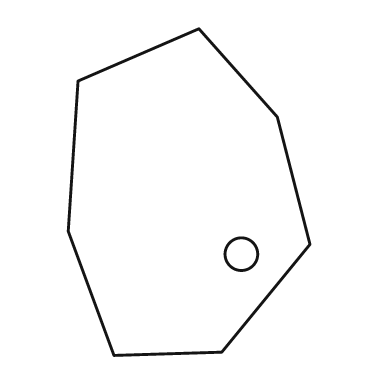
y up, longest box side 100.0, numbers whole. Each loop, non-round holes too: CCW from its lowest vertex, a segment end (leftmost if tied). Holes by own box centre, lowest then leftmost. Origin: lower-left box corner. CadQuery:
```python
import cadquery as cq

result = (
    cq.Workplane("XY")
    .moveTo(14.0, 0.0)
    .lineTo(47.0, 1.0)
    .lineTo(74.0, 34.0)
    .lineTo(64.0, 73.0)
    .lineTo(40.0, 100.0)
    .lineTo(3.0, 84.0)
    .lineTo(0.0, 38.0)
    .close()
    .moveTo(53.0, 31.0)
    .circle(5.0)
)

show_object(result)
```